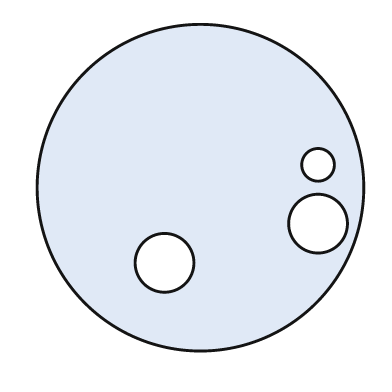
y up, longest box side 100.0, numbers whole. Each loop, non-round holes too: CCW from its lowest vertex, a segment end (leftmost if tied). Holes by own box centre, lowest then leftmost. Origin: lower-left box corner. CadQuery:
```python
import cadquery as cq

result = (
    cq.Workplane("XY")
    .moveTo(50.0, 50.0)
    .circle(50.0)
    .moveTo(39.0, 27.0)
    .circle(9.0)
    .moveTo(86.0, 39.0)
    .circle(9.0)
    .moveTo(86.0, 57.0)
    .circle(5.0)
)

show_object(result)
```